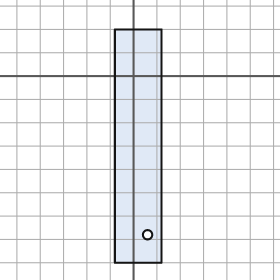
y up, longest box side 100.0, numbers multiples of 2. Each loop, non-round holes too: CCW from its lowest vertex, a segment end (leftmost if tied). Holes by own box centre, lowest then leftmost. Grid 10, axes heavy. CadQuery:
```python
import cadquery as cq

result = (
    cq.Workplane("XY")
    .moveTo(-8.0, -80.0)
    .lineTo(12.0, -80.0)
    .lineTo(12.0, 20.0)
    .lineTo(-8.0, 20.0)
    .close()
    .moveTo(6.0, -68.0)
    .circle(2.0)
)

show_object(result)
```